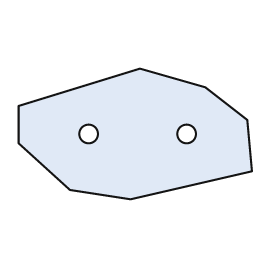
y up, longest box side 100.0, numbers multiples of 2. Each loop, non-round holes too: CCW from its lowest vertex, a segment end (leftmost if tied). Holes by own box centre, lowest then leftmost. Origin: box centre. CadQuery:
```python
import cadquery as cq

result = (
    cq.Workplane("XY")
    .moveTo(-2.0, -28.0)
    .lineTo(50.0, -16.0)
    .lineTo(48.0, 6.0)
    .lineTo(30.0, 20.0)
    .lineTo(2.0, 28.0)
    .lineTo(-50.0, 12.0)
    .lineTo(-50.0, -4.0)
    .lineTo(-28.0, -24.0)
    .close()
    .moveTo(-20.0, 0.0)
    .circle(4.0)
    .moveTo(22.0, 0.0)
    .circle(4.0)
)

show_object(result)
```